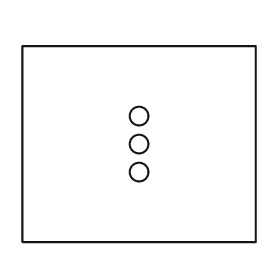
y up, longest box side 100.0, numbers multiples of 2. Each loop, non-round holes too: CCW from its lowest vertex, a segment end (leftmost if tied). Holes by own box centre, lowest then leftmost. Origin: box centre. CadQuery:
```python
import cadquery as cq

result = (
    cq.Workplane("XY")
    .moveTo(-50.0, -42.0)
    .lineTo(50.0, -42.0)
    .lineTo(50.0, 42.0)
    .lineTo(-50.0, 42.0)
    .close()
    .moveTo(0.0, -12.0)
    .circle(4.0)
    .moveTo(0.0, 0.0)
    .circle(4.0)
    .moveTo(0.0, 12.0)
    .circle(4.0)
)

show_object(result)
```